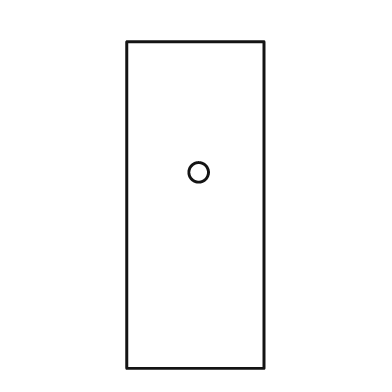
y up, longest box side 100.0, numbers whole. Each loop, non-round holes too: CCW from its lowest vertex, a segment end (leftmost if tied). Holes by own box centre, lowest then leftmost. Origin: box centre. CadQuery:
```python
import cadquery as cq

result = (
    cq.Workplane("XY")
    .moveTo(-21.0, -50.0)
    .lineTo(21.0, -50.0)
    .lineTo(21.0, 50.0)
    .lineTo(-21.0, 50.0)
    .close()
    .moveTo(1.0, 10.0)
    .circle(3.0)
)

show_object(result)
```